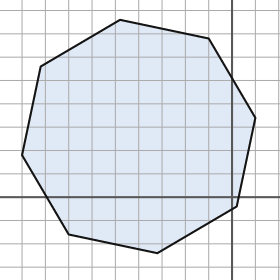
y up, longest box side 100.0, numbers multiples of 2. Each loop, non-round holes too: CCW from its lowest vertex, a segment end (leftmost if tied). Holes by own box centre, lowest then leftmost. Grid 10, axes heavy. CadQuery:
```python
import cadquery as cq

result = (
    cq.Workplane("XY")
    .moveTo(-32.0, -24.0)
    .lineTo(2.0, -4.0)
    .lineTo(10.0, 34.0)
    .lineTo(-10.0, 68.0)
    .lineTo(-48.0, 76.0)
    .lineTo(-82.0, 56.0)
    .lineTo(-90.0, 18.0)
    .lineTo(-70.0, -16.0)
    .close()
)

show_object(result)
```